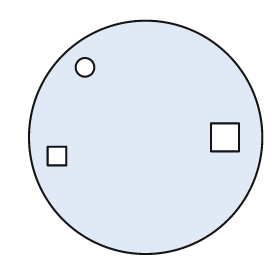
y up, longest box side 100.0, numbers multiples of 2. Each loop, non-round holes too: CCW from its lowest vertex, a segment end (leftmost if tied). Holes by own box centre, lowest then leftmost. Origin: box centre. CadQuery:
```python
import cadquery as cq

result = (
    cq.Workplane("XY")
    .moveTo(0.0, 0.0)
    .circle(50.0)
    .moveTo(-42.0, -12.0)
    .lineTo(-34.0, -12.0)
    .lineTo(-34.0, -4.0)
    .lineTo(-42.0, -4.0)
    .close()
    .moveTo(28.0, -6.0)
    .lineTo(40.0, -6.0)
    .lineTo(40.0, 6.0)
    .lineTo(28.0, 6.0)
    .close()
    .moveTo(-26.0, 30.0)
    .circle(4.0)
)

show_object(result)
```